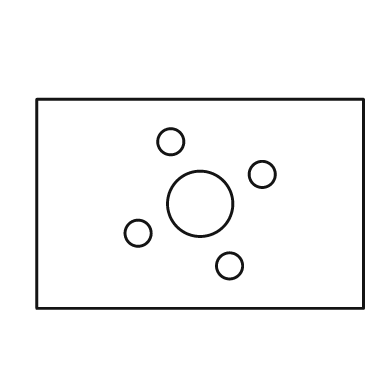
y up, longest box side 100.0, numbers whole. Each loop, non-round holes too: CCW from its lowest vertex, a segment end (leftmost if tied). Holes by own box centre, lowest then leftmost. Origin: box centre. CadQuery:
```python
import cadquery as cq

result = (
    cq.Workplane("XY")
    .moveTo(-50.0, -32.0)
    .lineTo(50.0, -32.0)
    .lineTo(50.0, 32.0)
    .lineTo(-50.0, 32.0)
    .close()
    .moveTo(9.0, -19.0)
    .circle(4.0)
    .moveTo(-19.0, -9.0)
    .circle(4.0)
    .moveTo(0.0, 0.0)
    .circle(10.0)
    .moveTo(19.0, 9.0)
    .circle(4.0)
    .moveTo(-9.0, 19.0)
    .circle(4.0)
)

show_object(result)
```